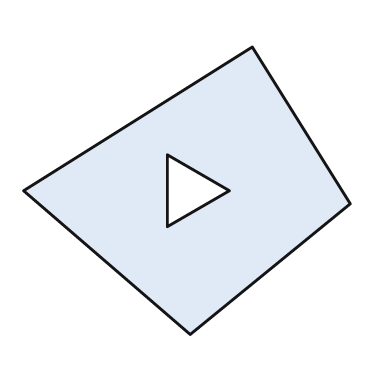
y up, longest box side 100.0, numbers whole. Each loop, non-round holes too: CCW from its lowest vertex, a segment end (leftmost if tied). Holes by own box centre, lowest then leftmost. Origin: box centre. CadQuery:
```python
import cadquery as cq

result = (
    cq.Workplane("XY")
    .moveTo(1.0, -44.0)
    .lineTo(50.0, -4.0)
    .lineTo(20.0, 44.0)
    .lineTo(-50.0, 0.0)
    .close()
    .moveTo(-6.0, -11.0)
    .lineTo(13.0, 0.0)
    .lineTo(-6.0, 11.0)
    .close()
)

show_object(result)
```